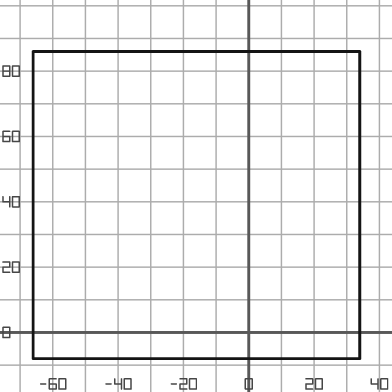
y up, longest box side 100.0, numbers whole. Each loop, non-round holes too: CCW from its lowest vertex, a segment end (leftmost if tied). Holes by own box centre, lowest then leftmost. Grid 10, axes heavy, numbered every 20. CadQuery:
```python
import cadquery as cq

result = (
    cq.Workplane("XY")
    .moveTo(-66.0, -8.0)
    .lineTo(34.0, -8.0)
    .lineTo(34.0, 86.0)
    .lineTo(-66.0, 86.0)
    .close()
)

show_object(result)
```